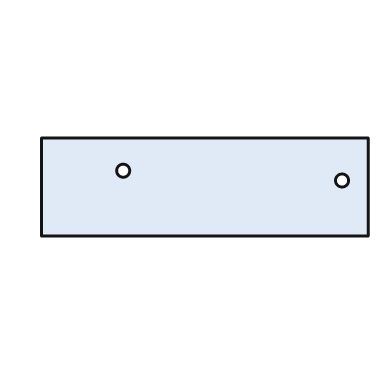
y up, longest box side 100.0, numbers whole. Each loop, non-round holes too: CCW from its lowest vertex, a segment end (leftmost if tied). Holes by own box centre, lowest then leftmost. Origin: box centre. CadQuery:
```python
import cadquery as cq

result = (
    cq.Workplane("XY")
    .moveTo(-50.0, -15.0)
    .lineTo(50.0, -15.0)
    .lineTo(50.0, 15.0)
    .lineTo(-50.0, 15.0)
    .close()
    .moveTo(42.0, 2.0)
    .circle(2.0)
    .moveTo(-25.0, 5.0)
    .circle(2.0)
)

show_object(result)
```